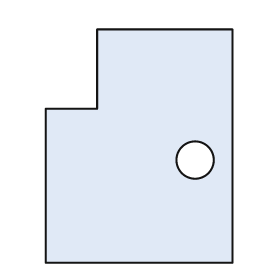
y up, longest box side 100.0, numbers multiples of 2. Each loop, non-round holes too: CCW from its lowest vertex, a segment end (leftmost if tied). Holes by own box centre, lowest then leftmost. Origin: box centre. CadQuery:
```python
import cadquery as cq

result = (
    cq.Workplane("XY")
    .moveTo(-40.0, -50.0)
    .lineTo(40.0, -50.0)
    .lineTo(40.0, 50.0)
    .lineTo(-18.0, 50.0)
    .lineTo(-18.0, 16.0)
    .lineTo(-40.0, 16.0)
    .close()
    .moveTo(24.0, -6.0)
    .circle(8.0)
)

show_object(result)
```